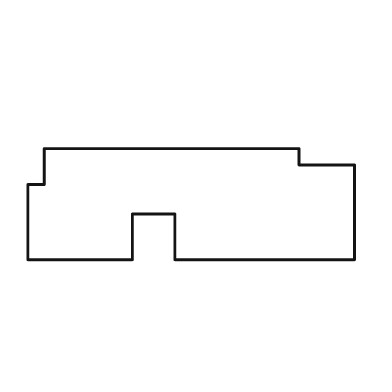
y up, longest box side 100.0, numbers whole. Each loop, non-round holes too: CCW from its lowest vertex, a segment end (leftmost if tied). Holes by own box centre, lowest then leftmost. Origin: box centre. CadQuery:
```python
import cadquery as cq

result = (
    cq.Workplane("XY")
    .moveTo(-50.0, -17.0)
    .lineTo(-18.0, -17.0)
    .lineTo(-18.0, -3.0)
    .lineTo(-5.0, -3.0)
    .lineTo(-5.0, -17.0)
    .lineTo(50.0, -17.0)
    .lineTo(50.0, 12.0)
    .lineTo(33.0, 12.0)
    .lineTo(33.0, 17.0)
    .lineTo(-45.0, 17.0)
    .lineTo(-45.0, 6.0)
    .lineTo(-50.0, 6.0)
    .close()
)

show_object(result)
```